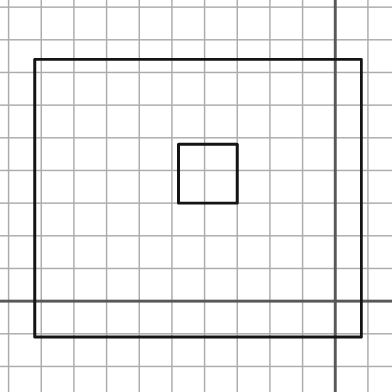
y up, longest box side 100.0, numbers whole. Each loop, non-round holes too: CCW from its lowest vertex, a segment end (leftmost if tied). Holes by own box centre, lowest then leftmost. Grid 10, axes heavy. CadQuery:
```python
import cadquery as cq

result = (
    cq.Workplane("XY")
    .moveTo(-92.0, -11.0)
    .lineTo(8.0, -11.0)
    .lineTo(8.0, 74.0)
    .lineTo(-92.0, 74.0)
    .close()
    .moveTo(-48.0, 30.0)
    .lineTo(-30.0, 30.0)
    .lineTo(-30.0, 48.0)
    .lineTo(-48.0, 48.0)
    .close()
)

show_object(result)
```